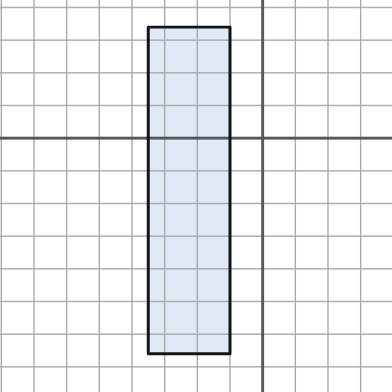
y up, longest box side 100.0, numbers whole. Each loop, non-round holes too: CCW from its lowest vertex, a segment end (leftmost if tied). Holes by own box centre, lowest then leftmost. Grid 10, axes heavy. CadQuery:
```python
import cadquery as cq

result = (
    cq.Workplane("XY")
    .moveTo(-35.0, -66.0)
    .lineTo(-10.0, -66.0)
    .lineTo(-10.0, 34.0)
    .lineTo(-35.0, 34.0)
    .close()
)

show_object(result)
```